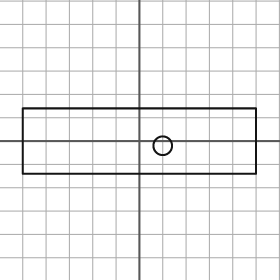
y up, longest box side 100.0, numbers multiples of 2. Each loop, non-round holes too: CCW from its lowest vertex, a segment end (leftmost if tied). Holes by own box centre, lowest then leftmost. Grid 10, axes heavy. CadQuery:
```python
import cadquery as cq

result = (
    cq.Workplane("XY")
    .moveTo(-50.0, -14.0)
    .lineTo(50.0, -14.0)
    .lineTo(50.0, 14.0)
    .lineTo(-50.0, 14.0)
    .close()
    .moveTo(10.0, -2.0)
    .circle(4.0)
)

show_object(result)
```